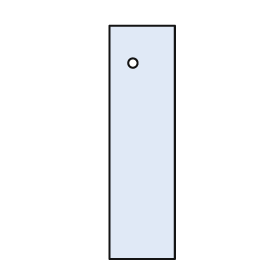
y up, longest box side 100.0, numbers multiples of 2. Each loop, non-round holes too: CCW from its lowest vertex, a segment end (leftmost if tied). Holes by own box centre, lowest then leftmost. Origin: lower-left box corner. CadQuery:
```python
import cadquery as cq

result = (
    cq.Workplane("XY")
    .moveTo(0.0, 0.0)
    .lineTo(28.0, 0.0)
    .lineTo(28.0, 100.0)
    .lineTo(0.0, 100.0)
    .close()
    .moveTo(10.0, 84.0)
    .circle(2.0)
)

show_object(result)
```